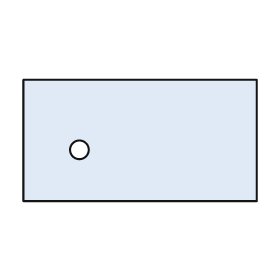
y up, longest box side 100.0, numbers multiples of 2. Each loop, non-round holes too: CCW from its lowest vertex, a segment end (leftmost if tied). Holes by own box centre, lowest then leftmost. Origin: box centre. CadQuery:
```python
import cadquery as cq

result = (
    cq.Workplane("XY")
    .moveTo(-50.0, -26.0)
    .lineTo(50.0, -26.0)
    .lineTo(50.0, 26.0)
    .lineTo(-50.0, 26.0)
    .close()
    .moveTo(-26.0, -4.0)
    .circle(4.0)
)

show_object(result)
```